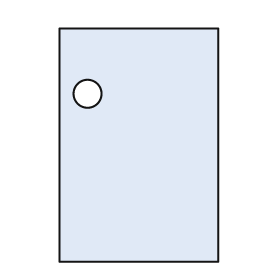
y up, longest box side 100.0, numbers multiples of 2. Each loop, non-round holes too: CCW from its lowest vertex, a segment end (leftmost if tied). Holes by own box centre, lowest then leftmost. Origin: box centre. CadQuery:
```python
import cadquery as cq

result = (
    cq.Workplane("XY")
    .moveTo(-34.0, -50.0)
    .lineTo(34.0, -50.0)
    .lineTo(34.0, 50.0)
    .lineTo(-34.0, 50.0)
    .close()
    .moveTo(-22.0, 22.0)
    .circle(6.0)
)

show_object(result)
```